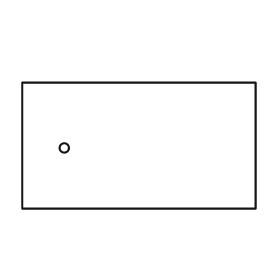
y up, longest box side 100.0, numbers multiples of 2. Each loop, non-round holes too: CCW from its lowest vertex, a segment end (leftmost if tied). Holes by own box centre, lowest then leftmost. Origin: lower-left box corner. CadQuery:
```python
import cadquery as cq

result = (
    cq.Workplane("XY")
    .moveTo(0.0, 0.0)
    .lineTo(100.0, 0.0)
    .lineTo(100.0, 54.0)
    .lineTo(0.0, 54.0)
    .close()
    .moveTo(18.0, 26.0)
    .circle(2.0)
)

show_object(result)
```